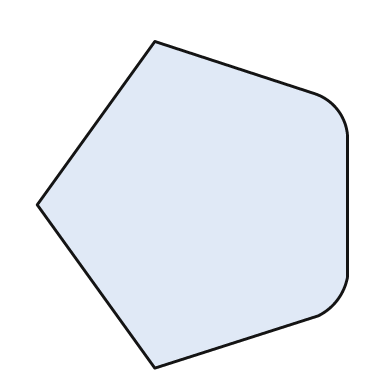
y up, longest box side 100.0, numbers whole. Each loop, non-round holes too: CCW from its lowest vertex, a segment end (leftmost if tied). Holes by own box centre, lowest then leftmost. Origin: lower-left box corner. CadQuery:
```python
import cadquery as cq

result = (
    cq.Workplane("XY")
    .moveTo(36.0, 0.0)
    .lineTo(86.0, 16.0)
    .threePointArc((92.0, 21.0), (95.0, 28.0))
    .lineTo(95.0, 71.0)
    .threePointArc((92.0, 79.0), (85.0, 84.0))
    .lineTo(36.0, 100.0)
    .lineTo(0.0, 50.0)
    .close()
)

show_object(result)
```